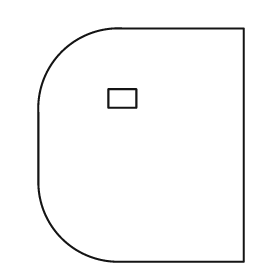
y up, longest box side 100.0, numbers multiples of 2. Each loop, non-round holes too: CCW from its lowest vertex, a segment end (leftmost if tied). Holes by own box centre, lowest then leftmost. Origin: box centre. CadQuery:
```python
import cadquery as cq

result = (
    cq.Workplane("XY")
    .moveTo(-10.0, -50.0)
    .lineTo(44.0, -50.0)
    .lineTo(44.0, 50.0)
    .lineTo(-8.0, 50.0)
    .threePointArc((-34.0, 40.0), (-44.0, 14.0))
    .lineTo(-44.0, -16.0)
    .threePointArc((-34.0, -40.0), (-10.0, -50.0))
    .close()
    .moveTo(-14.0, 16.0)
    .lineTo(-2.0, 16.0)
    .lineTo(-2.0, 24.0)
    .lineTo(-14.0, 24.0)
    .close()
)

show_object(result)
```